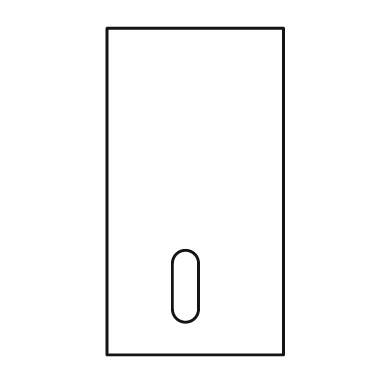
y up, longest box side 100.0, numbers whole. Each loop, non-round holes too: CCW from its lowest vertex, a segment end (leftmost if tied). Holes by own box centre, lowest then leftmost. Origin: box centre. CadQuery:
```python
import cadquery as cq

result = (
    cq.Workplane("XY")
    .moveTo(-27.0, -50.0)
    .lineTo(27.0, -50.0)
    .lineTo(27.0, 50.0)
    .lineTo(-27.0, 50.0)
    .close()
    .moveTo(-7.0, -36.0)
    .threePointArc((-3.0, -40.0), (1.0, -36.0))
    .lineTo(1.0, -22.0)
    .threePointArc((-3.0, -18.0), (-7.0, -22.0))
    .close()
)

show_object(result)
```